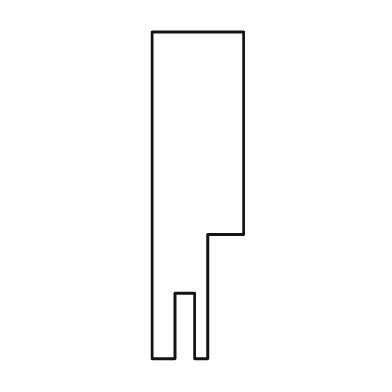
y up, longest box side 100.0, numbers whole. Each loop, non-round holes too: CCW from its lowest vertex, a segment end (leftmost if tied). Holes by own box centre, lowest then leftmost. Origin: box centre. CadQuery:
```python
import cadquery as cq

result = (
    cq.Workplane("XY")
    .moveTo(-14.0, -50.0)
    .lineTo(-7.0, -50.0)
    .lineTo(-7.0, -30.0)
    .lineTo(-1.0, -30.0)
    .lineTo(-1.0, -50.0)
    .lineTo(3.0, -50.0)
    .lineTo(3.0, -12.0)
    .lineTo(14.0, -12.0)
    .lineTo(14.0, 50.0)
    .lineTo(-14.0, 50.0)
    .close()
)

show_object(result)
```